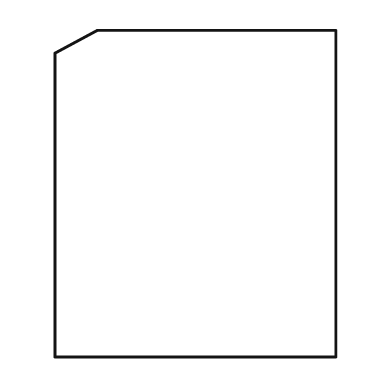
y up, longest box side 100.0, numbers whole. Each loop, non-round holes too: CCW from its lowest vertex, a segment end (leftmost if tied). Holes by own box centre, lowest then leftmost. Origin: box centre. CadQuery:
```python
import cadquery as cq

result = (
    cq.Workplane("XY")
    .moveTo(-43.0, -50.0)
    .lineTo(43.0, -50.0)
    .lineTo(43.0, 50.0)
    .lineTo(-30.0, 50.0)
    .lineTo(-43.0, 43.0)
    .close()
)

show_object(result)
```